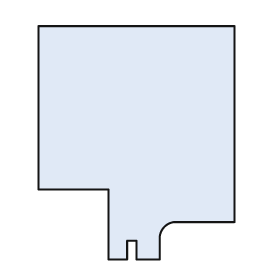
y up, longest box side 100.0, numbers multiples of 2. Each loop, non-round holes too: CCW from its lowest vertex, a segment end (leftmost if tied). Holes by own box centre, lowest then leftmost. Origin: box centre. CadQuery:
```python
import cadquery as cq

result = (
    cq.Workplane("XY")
    .moveTo(-12.0, -50.0)
    .lineTo(-4.0, -50.0)
    .lineTo(-4.0, -42.0)
    .lineTo(0.0, -42.0)
    .lineTo(0.0, -50.0)
    .lineTo(10.0, -50.0)
    .lineTo(10.0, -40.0)
    .threePointArc((12.0, -36.0), (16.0, -34.0))
    .lineTo(42.0, -34.0)
    .lineTo(42.0, 50.0)
    .lineTo(-42.0, 50.0)
    .lineTo(-42.0, -20.0)
    .lineTo(-12.0, -20.0)
    .close()
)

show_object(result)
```